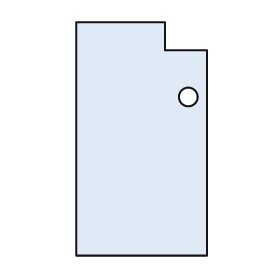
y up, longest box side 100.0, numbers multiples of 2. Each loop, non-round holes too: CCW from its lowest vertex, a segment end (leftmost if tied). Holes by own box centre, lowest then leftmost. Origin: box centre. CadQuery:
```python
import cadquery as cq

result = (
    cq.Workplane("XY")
    .moveTo(-28.0, -50.0)
    .lineTo(28.0, -50.0)
    .lineTo(28.0, 38.0)
    .lineTo(10.0, 38.0)
    .lineTo(10.0, 50.0)
    .lineTo(-28.0, 50.0)
    .close()
    .moveTo(20.0, 18.0)
    .circle(4.0)
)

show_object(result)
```